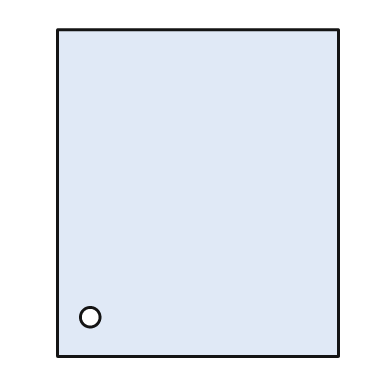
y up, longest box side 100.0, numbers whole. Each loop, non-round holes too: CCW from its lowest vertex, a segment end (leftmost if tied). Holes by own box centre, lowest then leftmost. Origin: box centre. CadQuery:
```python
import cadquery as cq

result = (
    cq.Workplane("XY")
    .moveTo(-43.0, -50.0)
    .lineTo(43.0, -50.0)
    .lineTo(43.0, 50.0)
    .lineTo(-43.0, 50.0)
    .close()
    .moveTo(-33.0, -38.0)
    .circle(3.0)
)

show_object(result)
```